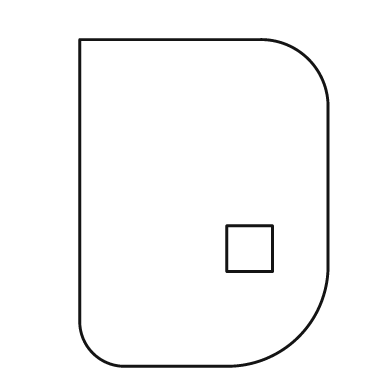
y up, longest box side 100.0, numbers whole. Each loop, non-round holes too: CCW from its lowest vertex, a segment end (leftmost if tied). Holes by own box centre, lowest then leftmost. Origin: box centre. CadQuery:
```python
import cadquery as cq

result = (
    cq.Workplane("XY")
    .moveTo(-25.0, -50.0)
    .lineTo(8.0, -50.0)
    .threePointArc((29.0, -41.0), (38.0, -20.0))
    .lineTo(38.0, 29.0)
    .threePointArc((32.0, 44.0), (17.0, 50.0))
    .lineTo(-38.0, 50.0)
    .lineTo(-38.0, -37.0)
    .threePointArc((-34.0, -46.0), (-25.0, -50.0))
    .close()
    .moveTo(7.0, -21.0)
    .lineTo(21.0, -21.0)
    .lineTo(21.0, -7.0)
    .lineTo(7.0, -7.0)
    .close()
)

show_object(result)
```